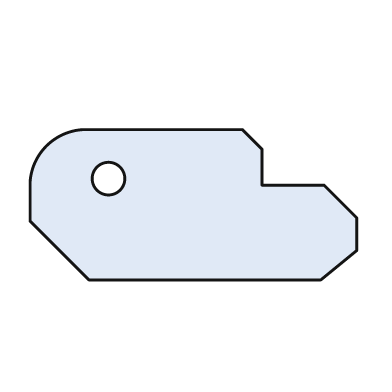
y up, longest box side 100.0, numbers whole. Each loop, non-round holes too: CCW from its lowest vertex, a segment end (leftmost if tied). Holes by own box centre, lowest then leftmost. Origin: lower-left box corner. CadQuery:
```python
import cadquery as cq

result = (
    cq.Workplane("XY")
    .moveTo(18.0, 0.0)
    .lineTo(89.0, 0.0)
    .lineTo(100.0, 9.0)
    .lineTo(100.0, 19.0)
    .lineTo(90.0, 29.0)
    .lineTo(71.0, 29.0)
    .lineTo(71.0, 40.0)
    .lineTo(65.0, 46.0)
    .lineTo(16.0, 46.0)
    .threePointArc((5.0, 41.0), (0.0, 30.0))
    .lineTo(0.0, 18.0)
    .close()
    .moveTo(24.0, 31.0)
    .circle(5.0)
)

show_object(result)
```